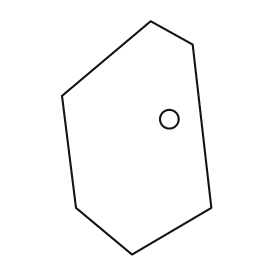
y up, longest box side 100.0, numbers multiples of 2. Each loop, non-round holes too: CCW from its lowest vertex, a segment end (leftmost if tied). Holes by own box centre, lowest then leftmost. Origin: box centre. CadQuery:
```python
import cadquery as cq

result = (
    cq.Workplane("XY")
    .moveTo(-2.0, -50.0)
    .lineTo(32.0, -30.0)
    .lineTo(24.0, 40.0)
    .lineTo(6.0, 50.0)
    .lineTo(-32.0, 18.0)
    .lineTo(-26.0, -30.0)
    .close()
    .moveTo(14.0, 8.0)
    .circle(4.0)
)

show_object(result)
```